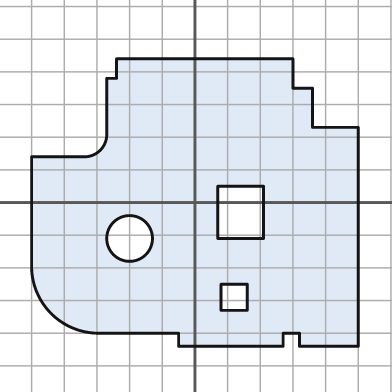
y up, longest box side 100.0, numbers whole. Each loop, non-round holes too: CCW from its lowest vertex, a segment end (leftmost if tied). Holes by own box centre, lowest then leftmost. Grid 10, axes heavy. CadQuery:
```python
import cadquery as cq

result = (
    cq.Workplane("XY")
    .moveTo(-5.0, -44.0)
    .lineTo(27.0, -44.0)
    .lineTo(27.0, -40.0)
    .lineTo(32.0, -40.0)
    .lineTo(32.0, -44.0)
    .lineTo(50.0, -44.0)
    .lineTo(50.0, 23.0)
    .lineTo(36.0, 23.0)
    .lineTo(36.0, 35.0)
    .lineTo(30.0, 35.0)
    .lineTo(30.0, 44.0)
    .lineTo(-24.0, 44.0)
    .lineTo(-24.0, 38.0)
    .lineTo(-27.0, 38.0)
    .lineTo(-27.0, 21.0)
    .threePointArc((-29.0, 16.0), (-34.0, 14.0))
    .lineTo(-50.0, 14.0)
    .lineTo(-50.0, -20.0)
    .threePointArc((-44.0, -34.0), (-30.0, -40.0))
    .lineTo(-5.0, -40.0)
    .close()
    .moveTo(8.0, -33.0)
    .lineTo(16.0, -33.0)
    .lineTo(16.0, -25.0)
    .lineTo(8.0, -25.0)
    .close()
    .moveTo(-20.0, -11.0)
    .circle(7.0)
    .moveTo(7.0, -11.0)
    .lineTo(21.0, -11.0)
    .lineTo(21.0, 5.0)
    .lineTo(7.0, 5.0)
    .close()
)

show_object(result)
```